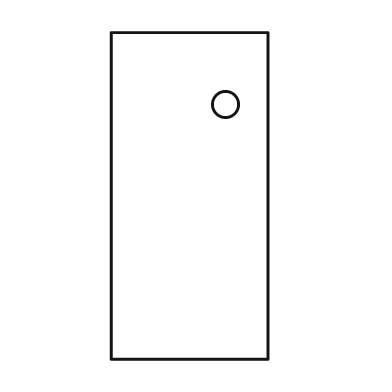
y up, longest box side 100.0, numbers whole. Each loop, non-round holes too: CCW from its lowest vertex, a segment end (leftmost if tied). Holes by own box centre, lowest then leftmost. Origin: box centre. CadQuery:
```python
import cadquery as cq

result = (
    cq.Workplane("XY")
    .moveTo(-24.0, -50.0)
    .lineTo(24.0, -50.0)
    .lineTo(24.0, 50.0)
    .lineTo(-24.0, 50.0)
    .close()
    .moveTo(11.0, 28.0)
    .circle(4.0)
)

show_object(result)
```